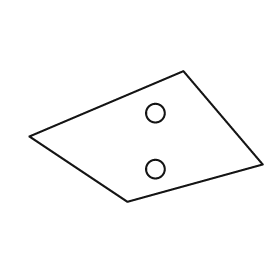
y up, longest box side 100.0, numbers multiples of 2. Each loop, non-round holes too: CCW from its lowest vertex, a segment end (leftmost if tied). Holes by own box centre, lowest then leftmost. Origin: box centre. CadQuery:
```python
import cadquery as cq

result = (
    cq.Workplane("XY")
    .moveTo(-8.0, -28.0)
    .lineTo(50.0, -12.0)
    .lineTo(16.0, 28.0)
    .lineTo(-50.0, 0.0)
    .close()
    .moveTo(4.0, -14.0)
    .circle(4.0)
    .moveTo(4.0, 10.0)
    .circle(4.0)
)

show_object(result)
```